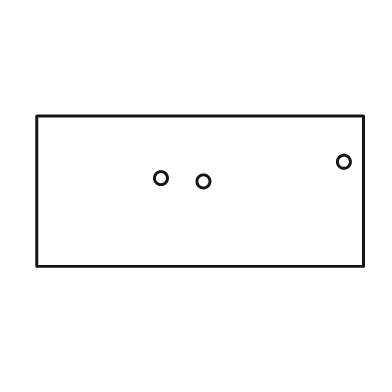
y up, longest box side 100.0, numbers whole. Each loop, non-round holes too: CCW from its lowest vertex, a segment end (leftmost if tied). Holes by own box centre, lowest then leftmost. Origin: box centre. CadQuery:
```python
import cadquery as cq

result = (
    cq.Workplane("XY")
    .moveTo(-50.0, -23.0)
    .lineTo(50.0, -23.0)
    .lineTo(50.0, 23.0)
    .lineTo(-50.0, 23.0)
    .close()
    .moveTo(1.0, 3.0)
    .circle(2.0)
    .moveTo(-12.0, 4.0)
    .circle(2.0)
    .moveTo(44.0, 9.0)
    .circle(2.0)
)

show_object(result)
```